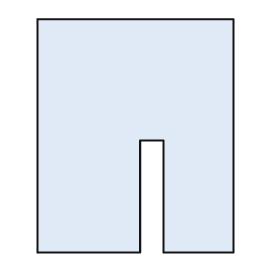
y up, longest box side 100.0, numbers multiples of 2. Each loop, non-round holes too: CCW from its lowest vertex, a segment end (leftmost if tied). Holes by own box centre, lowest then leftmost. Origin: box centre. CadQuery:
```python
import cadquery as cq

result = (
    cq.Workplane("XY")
    .moveTo(-42.0, -50.0)
    .lineTo(2.0, -50.0)
    .lineTo(2.0, -2.0)
    .lineTo(12.0, -2.0)
    .lineTo(12.0, -50.0)
    .lineTo(42.0, -50.0)
    .lineTo(42.0, 50.0)
    .lineTo(-42.0, 50.0)
    .close()
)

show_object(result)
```